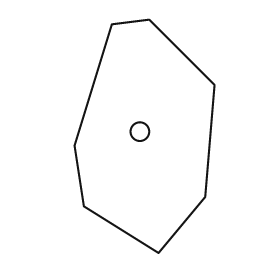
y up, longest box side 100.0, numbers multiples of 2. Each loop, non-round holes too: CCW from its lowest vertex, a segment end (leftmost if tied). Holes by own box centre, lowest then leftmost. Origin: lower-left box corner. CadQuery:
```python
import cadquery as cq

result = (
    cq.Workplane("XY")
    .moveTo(36.0, 0.0)
    .lineTo(56.0, 24.0)
    .lineTo(60.0, 72.0)
    .lineTo(32.0, 100.0)
    .lineTo(16.0, 98.0)
    .lineTo(0.0, 46.0)
    .lineTo(4.0, 20.0)
    .close()
    .moveTo(28.0, 52.0)
    .circle(4.0)
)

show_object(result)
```